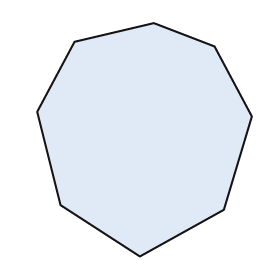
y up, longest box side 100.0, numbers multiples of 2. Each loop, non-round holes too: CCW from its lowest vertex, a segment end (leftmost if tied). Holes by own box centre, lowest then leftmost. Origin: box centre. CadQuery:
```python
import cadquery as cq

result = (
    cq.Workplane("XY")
    .moveTo(-2.0, -50.0)
    .lineTo(34.0, -30.0)
    .lineTo(46.0, 10.0)
    .lineTo(30.0, 40.0)
    .lineTo(4.0, 50.0)
    .lineTo(-30.0, 42.0)
    .lineTo(-46.0, 12.0)
    .lineTo(-36.0, -28.0)
    .close()
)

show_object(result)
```